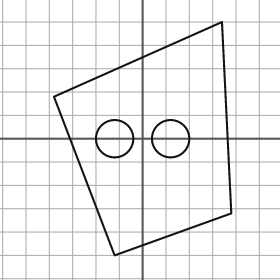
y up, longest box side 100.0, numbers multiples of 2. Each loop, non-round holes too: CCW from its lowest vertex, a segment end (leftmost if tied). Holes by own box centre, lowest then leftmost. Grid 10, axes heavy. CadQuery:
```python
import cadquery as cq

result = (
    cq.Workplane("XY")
    .moveTo(-12.0, -50.0)
    .lineTo(38.0, -32.0)
    .lineTo(34.0, 50.0)
    .lineTo(-38.0, 18.0)
    .close()
    .moveTo(-12.0, 0.0)
    .circle(8.0)
    .moveTo(12.0, 0.0)
    .circle(8.0)
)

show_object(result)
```